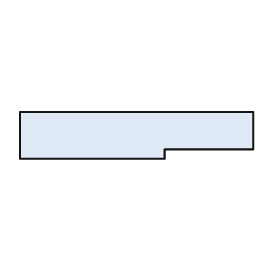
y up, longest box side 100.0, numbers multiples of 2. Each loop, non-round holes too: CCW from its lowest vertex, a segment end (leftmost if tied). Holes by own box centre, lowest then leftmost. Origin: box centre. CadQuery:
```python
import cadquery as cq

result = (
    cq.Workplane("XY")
    .moveTo(-50.0, -10.0)
    .lineTo(12.0, -10.0)
    .lineTo(12.0, -6.0)
    .lineTo(50.0, -6.0)
    .lineTo(50.0, 10.0)
    .lineTo(-50.0, 10.0)
    .close()
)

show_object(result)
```